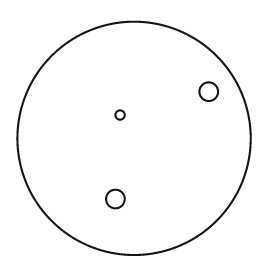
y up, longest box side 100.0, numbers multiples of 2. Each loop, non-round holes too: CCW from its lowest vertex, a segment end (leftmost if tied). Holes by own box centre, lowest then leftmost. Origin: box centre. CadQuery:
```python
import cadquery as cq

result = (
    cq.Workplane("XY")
    .moveTo(0.0, 0.0)
    .circle(50.0)
    .moveTo(-8.0, -26.0)
    .circle(4.0)
    .moveTo(-6.0, 10.0)
    .circle(2.0)
    .moveTo(32.0, 20.0)
    .circle(4.0)
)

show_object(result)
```